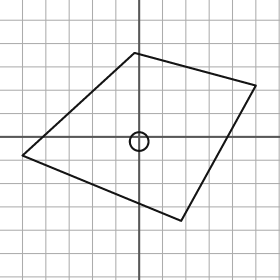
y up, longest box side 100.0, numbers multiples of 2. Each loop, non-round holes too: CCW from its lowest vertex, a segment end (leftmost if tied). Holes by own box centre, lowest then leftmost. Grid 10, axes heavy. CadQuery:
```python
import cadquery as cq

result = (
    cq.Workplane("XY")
    .moveTo(18.0, -36.0)
    .lineTo(50.0, 22.0)
    .lineTo(-2.0, 36.0)
    .lineTo(-50.0, -8.0)
    .close()
    .moveTo(0.0, -2.0)
    .circle(4.0)
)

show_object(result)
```